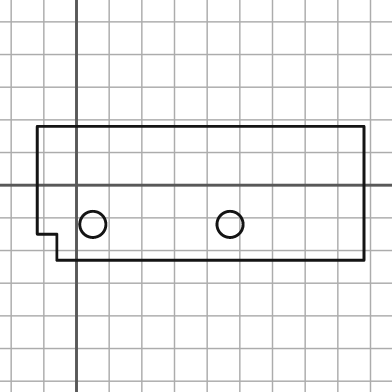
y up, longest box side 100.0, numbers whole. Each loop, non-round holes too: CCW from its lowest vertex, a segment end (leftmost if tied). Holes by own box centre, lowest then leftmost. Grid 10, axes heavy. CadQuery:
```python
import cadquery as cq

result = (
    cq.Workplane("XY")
    .moveTo(-6.0, -23.0)
    .lineTo(88.0, -23.0)
    .lineTo(88.0, 18.0)
    .lineTo(-12.0, 18.0)
    .lineTo(-12.0, -15.0)
    .lineTo(-6.0, -15.0)
    .close()
    .moveTo(5.0, -12.0)
    .circle(4.0)
    .moveTo(47.0, -12.0)
    .circle(4.0)
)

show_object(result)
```